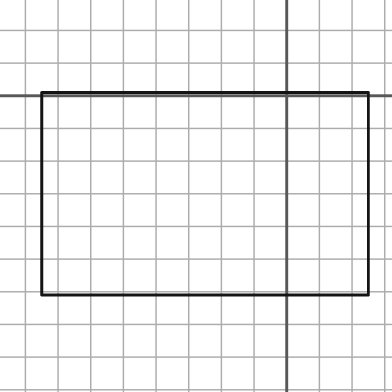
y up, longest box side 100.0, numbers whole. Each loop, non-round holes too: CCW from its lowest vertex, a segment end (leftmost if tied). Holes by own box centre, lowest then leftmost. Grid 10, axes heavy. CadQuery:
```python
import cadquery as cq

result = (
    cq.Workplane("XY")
    .moveTo(-75.0, -61.0)
    .lineTo(25.0, -61.0)
    .lineTo(25.0, 1.0)
    .lineTo(-75.0, 1.0)
    .close()
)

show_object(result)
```